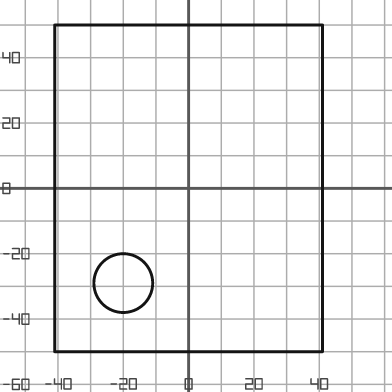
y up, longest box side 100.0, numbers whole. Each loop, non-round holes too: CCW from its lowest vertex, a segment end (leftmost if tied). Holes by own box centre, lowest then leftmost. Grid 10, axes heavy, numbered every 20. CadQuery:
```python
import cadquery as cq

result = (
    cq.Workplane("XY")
    .moveTo(-41.0, -50.0)
    .lineTo(41.0, -50.0)
    .lineTo(41.0, 50.0)
    .lineTo(-41.0, 50.0)
    .close()
    .moveTo(-20.0, -29.0)
    .circle(9.0)
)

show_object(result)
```